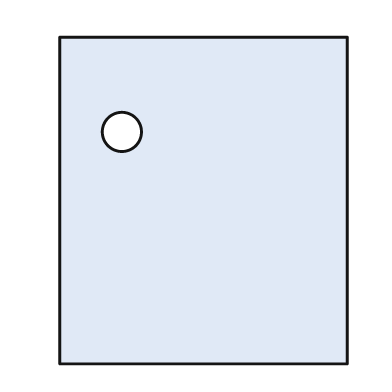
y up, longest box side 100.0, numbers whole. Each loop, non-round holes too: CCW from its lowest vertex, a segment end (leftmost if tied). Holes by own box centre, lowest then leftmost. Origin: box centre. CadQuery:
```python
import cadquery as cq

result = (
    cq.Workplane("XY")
    .moveTo(-44.0, -50.0)
    .lineTo(44.0, -50.0)
    .lineTo(44.0, 50.0)
    .lineTo(-44.0, 50.0)
    .close()
    .moveTo(-25.0, 21.0)
    .circle(6.0)
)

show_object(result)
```